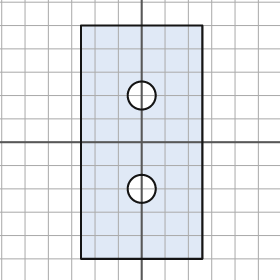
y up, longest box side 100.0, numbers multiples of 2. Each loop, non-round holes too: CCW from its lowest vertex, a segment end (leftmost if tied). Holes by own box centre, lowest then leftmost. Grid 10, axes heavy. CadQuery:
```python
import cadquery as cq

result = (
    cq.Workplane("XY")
    .moveTo(-26.0, -50.0)
    .lineTo(26.0, -50.0)
    .lineTo(26.0, 50.0)
    .lineTo(-26.0, 50.0)
    .close()
    .moveTo(0.0, -20.0)
    .circle(6.0)
    .moveTo(0.0, 20.0)
    .circle(6.0)
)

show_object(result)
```